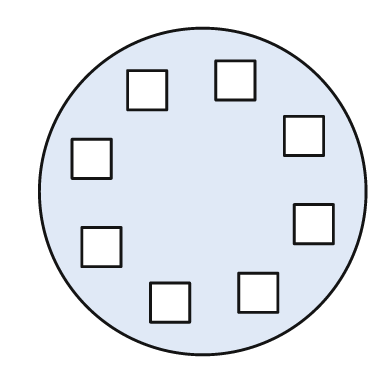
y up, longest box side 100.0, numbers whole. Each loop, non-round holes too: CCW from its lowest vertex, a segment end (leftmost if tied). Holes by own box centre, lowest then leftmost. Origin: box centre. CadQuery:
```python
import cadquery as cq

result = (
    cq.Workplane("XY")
    .moveTo(0.0, 0.0)
    .circle(50.0)
    .moveTo(-16.0, -40.0)
    .lineTo(-4.0, -40.0)
    .lineTo(-4.0, -28.0)
    .lineTo(-16.0, -28.0)
    .close()
    .moveTo(11.0, -37.0)
    .lineTo(23.0, -37.0)
    .lineTo(23.0, -25.0)
    .lineTo(11.0, -25.0)
    .close()
    .moveTo(-37.0, -23.0)
    .lineTo(-25.0, -23.0)
    .lineTo(-25.0, -11.0)
    .lineTo(-37.0, -11.0)
    .close()
    .moveTo(28.0, -16.0)
    .lineTo(40.0, -16.0)
    .lineTo(40.0, -4.0)
    .lineTo(28.0, -4.0)
    .close()
    .moveTo(-40.0, 4.0)
    .lineTo(-28.0, 4.0)
    .lineTo(-28.0, 16.0)
    .lineTo(-40.0, 16.0)
    .close()
    .moveTo(25.0, 11.0)
    .lineTo(37.0, 11.0)
    .lineTo(37.0, 23.0)
    .lineTo(25.0, 23.0)
    .close()
    .moveTo(-23.0, 25.0)
    .lineTo(-11.0, 25.0)
    .lineTo(-11.0, 37.0)
    .lineTo(-23.0, 37.0)
    .close()
    .moveTo(4.0, 28.0)
    .lineTo(16.0, 28.0)
    .lineTo(16.0, 40.0)
    .lineTo(4.0, 40.0)
    .close()
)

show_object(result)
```